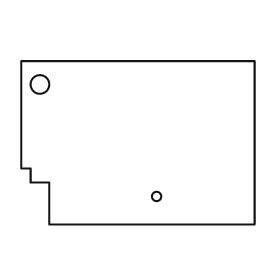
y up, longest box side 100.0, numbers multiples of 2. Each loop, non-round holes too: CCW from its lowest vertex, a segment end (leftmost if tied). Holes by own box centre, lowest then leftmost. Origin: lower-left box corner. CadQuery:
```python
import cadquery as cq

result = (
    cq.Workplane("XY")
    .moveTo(12.0, 0.0)
    .lineTo(100.0, 0.0)
    .lineTo(100.0, 70.0)
    .lineTo(0.0, 70.0)
    .lineTo(0.0, 24.0)
    .lineTo(4.0, 24.0)
    .lineTo(4.0, 18.0)
    .lineTo(12.0, 18.0)
    .close()
    .moveTo(58.0, 12.0)
    .circle(2.0)
    .moveTo(8.0, 60.0)
    .circle(4.0)
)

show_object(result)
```